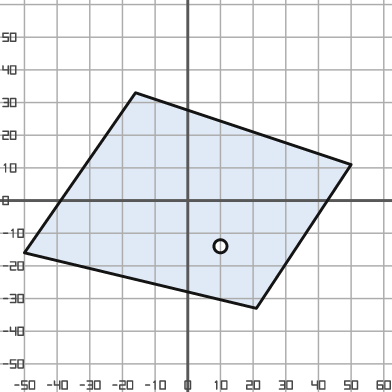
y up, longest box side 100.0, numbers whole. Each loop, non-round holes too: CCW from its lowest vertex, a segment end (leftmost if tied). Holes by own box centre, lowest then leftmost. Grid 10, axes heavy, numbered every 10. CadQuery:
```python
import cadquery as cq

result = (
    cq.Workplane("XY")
    .moveTo(21.0, -33.0)
    .lineTo(50.0, 11.0)
    .lineTo(-16.0, 33.0)
    .lineTo(-50.0, -16.0)
    .close()
    .moveTo(10.0, -14.0)
    .circle(2.0)
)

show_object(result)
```